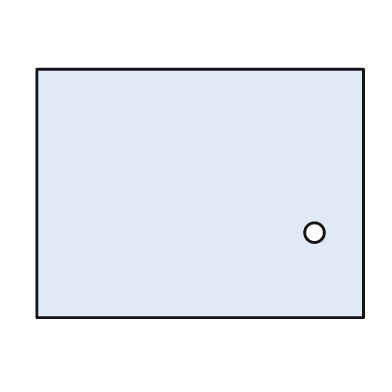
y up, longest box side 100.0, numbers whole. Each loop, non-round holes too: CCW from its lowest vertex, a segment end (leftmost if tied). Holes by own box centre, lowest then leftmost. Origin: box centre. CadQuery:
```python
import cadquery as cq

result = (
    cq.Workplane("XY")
    .moveTo(-50.0, -38.0)
    .lineTo(50.0, -38.0)
    .lineTo(50.0, 38.0)
    .lineTo(-50.0, 38.0)
    .close()
    .moveTo(35.0, -12.0)
    .circle(3.0)
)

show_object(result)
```